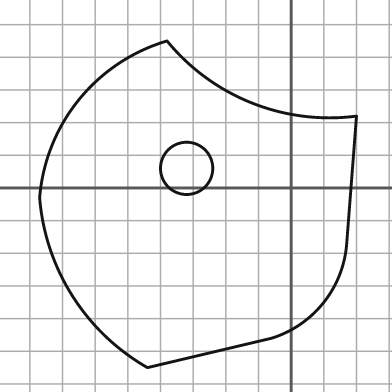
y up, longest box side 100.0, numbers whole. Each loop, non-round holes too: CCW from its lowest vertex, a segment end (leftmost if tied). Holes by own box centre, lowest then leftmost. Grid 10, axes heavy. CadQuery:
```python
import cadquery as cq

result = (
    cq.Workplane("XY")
    .moveTo(-44.0, -55.0)
    .lineTo(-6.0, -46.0)
    .threePointArc((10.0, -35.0), (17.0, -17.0))
    .lineTo(20.0, 22.0)
    .threePointArc((-12.0, 26.0), (-38.0, 45.0))
    .threePointArc((-65.0, 27.0), (-77.0, -3.0))
    .threePointArc((-67.0, -33.0), (-44.0, -55.0))
    .close()
    .moveTo(-32.0, 6.0)
    .circle(8.0)
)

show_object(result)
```